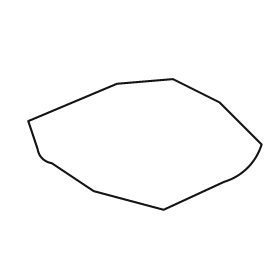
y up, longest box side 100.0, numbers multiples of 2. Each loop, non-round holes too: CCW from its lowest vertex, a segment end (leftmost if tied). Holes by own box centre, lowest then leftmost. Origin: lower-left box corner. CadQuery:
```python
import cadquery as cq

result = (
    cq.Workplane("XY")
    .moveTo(58.0, 0.0)
    .lineTo(84.0, 12.0)
    .threePointArc((94.0, 18.0), (100.0, 28.0))
    .lineTo(82.0, 46.0)
    .lineTo(62.0, 56.0)
    .lineTo(38.0, 54.0)
    .lineTo(0.0, 38.0)
    .lineTo(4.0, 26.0)
    .threePointArc((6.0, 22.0), (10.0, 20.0))
    .lineTo(28.0, 8.0)
    .close()
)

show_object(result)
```